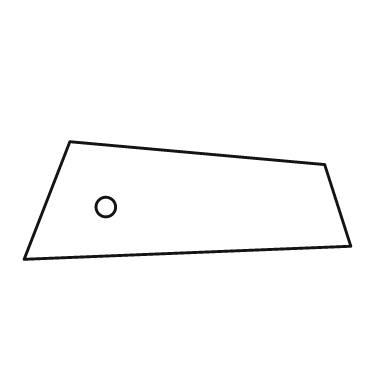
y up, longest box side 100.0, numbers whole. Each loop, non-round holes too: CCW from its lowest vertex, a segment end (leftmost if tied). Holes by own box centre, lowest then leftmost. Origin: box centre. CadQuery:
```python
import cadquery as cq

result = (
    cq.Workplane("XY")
    .moveTo(-50.0, -18.0)
    .lineTo(50.0, -14.0)
    .lineTo(42.0, 11.0)
    .lineTo(-36.0, 18.0)
    .close()
    .moveTo(-25.0, -2.0)
    .circle(3.0)
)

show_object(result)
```